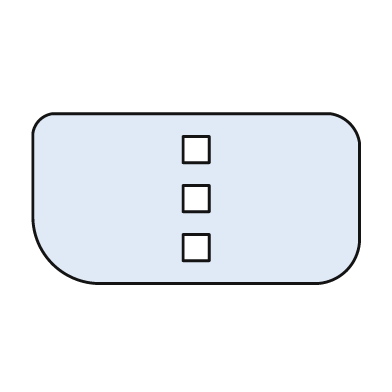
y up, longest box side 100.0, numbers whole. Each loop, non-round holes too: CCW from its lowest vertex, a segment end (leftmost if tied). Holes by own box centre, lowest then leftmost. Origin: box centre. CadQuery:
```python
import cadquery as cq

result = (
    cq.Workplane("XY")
    .moveTo(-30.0, -26.0)
    .lineTo(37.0, -26.0)
    .threePointArc((46.0, -22.0), (50.0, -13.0))
    .lineTo(50.0, 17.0)
    .threePointArc((47.0, 23.0), (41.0, 26.0))
    .lineTo(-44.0, 26.0)
    .threePointArc((-48.0, 24.0), (-50.0, 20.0))
    .lineTo(-50.0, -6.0)
    .threePointArc((-44.0, -20.0), (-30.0, -26.0))
    .close()
    .moveTo(-4.0, -19.0)
    .lineTo(4.0, -19.0)
    .lineTo(4.0, -11.0)
    .lineTo(-4.0, -11.0)
    .close()
    .moveTo(-4.0, -4.0)
    .lineTo(4.0, -4.0)
    .lineTo(4.0, 4.0)
    .lineTo(-4.0, 4.0)
    .close()
    .moveTo(-4.0, 11.0)
    .lineTo(4.0, 11.0)
    .lineTo(4.0, 19.0)
    .lineTo(-4.0, 19.0)
    .close()
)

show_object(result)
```